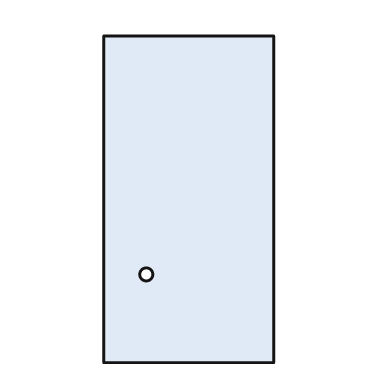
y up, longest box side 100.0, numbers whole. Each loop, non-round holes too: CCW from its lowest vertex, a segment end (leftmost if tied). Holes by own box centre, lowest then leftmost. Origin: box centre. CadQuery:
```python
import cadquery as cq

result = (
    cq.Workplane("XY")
    .moveTo(-26.0, -50.0)
    .lineTo(26.0, -50.0)
    .lineTo(26.0, 50.0)
    .lineTo(-26.0, 50.0)
    .close()
    .moveTo(-13.0, -23.0)
    .circle(2.0)
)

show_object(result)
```